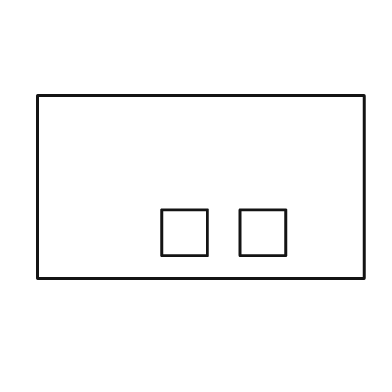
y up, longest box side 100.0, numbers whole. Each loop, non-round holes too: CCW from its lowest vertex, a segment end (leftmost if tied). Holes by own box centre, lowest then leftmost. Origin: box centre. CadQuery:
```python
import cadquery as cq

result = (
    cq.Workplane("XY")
    .moveTo(-50.0, -28.0)
    .lineTo(50.0, -28.0)
    .lineTo(50.0, 28.0)
    .lineTo(-50.0, 28.0)
    .close()
    .moveTo(-12.0, -21.0)
    .lineTo(2.0, -21.0)
    .lineTo(2.0, -7.0)
    .lineTo(-12.0, -7.0)
    .close()
    .moveTo(12.0, -21.0)
    .lineTo(26.0, -21.0)
    .lineTo(26.0, -7.0)
    .lineTo(12.0, -7.0)
    .close()
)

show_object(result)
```